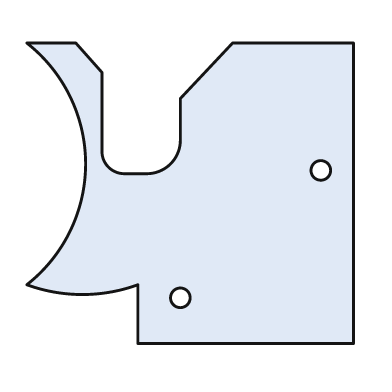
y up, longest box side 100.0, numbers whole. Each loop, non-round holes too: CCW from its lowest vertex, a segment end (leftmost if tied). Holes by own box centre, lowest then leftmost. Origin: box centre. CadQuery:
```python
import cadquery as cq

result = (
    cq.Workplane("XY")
    .moveTo(-16.0, -46.0)
    .lineTo(50.0, -46.0)
    .lineTo(50.0, 46.0)
    .lineTo(13.0, 46.0)
    .lineTo(-3.0, 29.0)
    .lineTo(-3.0, 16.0)
    .threePointArc((-6.0, 9.0), (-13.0, 6.0))
    .lineTo(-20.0, 6.0)
    .threePointArc((-25.0, 8.0), (-27.0, 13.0))
    .lineTo(-27.0, 37.0)
    .lineTo(-35.0, 46.0)
    .lineTo(-50.0, 46.0)
    .threePointArc((-32.0, 9.0), (-50.0, -28.0))
    .threePointArc((-33.0, -31.0), (-16.0, -28.0))
    .close()
    .moveTo(-3.0, -32.0)
    .circle(3.0)
    .moveTo(40.0, 7.0)
    .circle(3.0)
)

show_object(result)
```